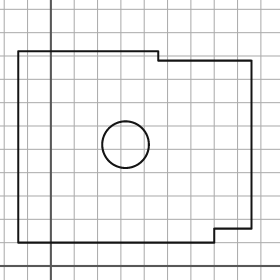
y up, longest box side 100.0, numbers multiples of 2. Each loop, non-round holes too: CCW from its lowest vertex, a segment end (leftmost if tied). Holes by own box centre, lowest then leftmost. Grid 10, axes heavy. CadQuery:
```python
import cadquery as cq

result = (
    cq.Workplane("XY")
    .moveTo(-14.0, 10.0)
    .lineTo(70.0, 10.0)
    .lineTo(70.0, 16.0)
    .lineTo(86.0, 16.0)
    .lineTo(86.0, 88.0)
    .lineTo(46.0, 88.0)
    .lineTo(46.0, 92.0)
    .lineTo(-14.0, 92.0)
    .close()
    .moveTo(32.0, 52.0)
    .circle(10.0)
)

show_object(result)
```